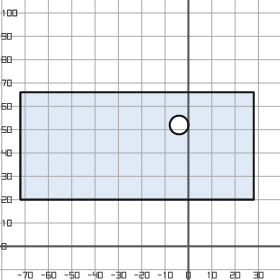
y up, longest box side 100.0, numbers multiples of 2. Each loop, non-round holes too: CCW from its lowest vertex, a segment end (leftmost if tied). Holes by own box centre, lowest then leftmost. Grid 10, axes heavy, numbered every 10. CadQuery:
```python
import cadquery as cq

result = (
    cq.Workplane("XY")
    .moveTo(-72.0, 20.0)
    .lineTo(28.0, 20.0)
    .lineTo(28.0, 66.0)
    .lineTo(-72.0, 66.0)
    .close()
    .moveTo(-4.0, 52.0)
    .circle(4.0)
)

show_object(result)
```